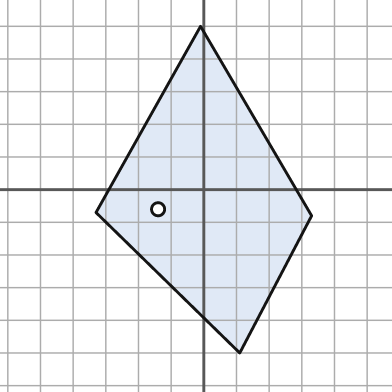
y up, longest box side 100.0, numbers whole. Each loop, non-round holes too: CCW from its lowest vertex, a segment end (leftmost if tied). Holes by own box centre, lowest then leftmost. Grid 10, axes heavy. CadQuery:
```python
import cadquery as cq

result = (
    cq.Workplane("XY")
    .moveTo(11.0, -50.0)
    .lineTo(33.0, -8.0)
    .lineTo(-1.0, 50.0)
    .lineTo(-33.0, -7.0)
    .close()
    .moveTo(-14.0, -6.0)
    .circle(2.0)
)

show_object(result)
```